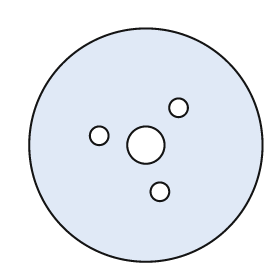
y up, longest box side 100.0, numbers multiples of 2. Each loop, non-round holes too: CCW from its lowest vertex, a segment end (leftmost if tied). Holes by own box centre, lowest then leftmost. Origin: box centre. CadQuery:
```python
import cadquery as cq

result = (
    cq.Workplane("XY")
    .moveTo(0.0, 0.0)
    .circle(50.0)
    .moveTo(6.0, -20.0)
    .circle(4.0)
    .moveTo(0.0, 0.0)
    .circle(8.0)
    .moveTo(-20.0, 4.0)
    .circle(4.0)
    .moveTo(14.0, 16.0)
    .circle(4.0)
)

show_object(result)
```